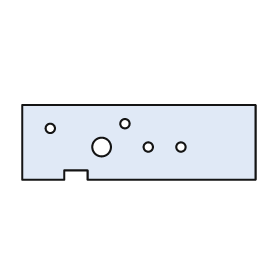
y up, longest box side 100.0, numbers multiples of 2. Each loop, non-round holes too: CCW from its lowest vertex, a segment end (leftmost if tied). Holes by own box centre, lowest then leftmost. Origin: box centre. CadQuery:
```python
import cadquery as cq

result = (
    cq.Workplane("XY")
    .moveTo(-50.0, -16.0)
    .lineTo(-32.0, -16.0)
    .lineTo(-32.0, -12.0)
    .lineTo(-22.0, -12.0)
    .lineTo(-22.0, -16.0)
    .lineTo(50.0, -16.0)
    .lineTo(50.0, 16.0)
    .lineTo(-50.0, 16.0)
    .close()
    .moveTo(-16.0, -2.0)
    .circle(4.0)
    .moveTo(4.0, -2.0)
    .circle(2.0)
    .moveTo(18.0, -2.0)
    .circle(2.0)
    .moveTo(-38.0, 6.0)
    .circle(2.0)
    .moveTo(-6.0, 8.0)
    .circle(2.0)
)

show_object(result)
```